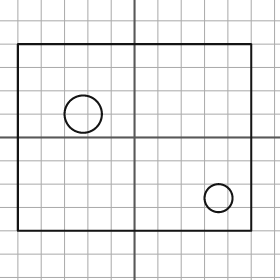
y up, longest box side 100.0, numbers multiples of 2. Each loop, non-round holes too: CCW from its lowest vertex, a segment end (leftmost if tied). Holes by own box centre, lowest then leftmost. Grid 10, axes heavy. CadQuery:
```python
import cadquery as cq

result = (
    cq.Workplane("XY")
    .moveTo(-50.0, -40.0)
    .lineTo(50.0, -40.0)
    .lineTo(50.0, 40.0)
    .lineTo(-50.0, 40.0)
    .close()
    .moveTo(36.0, -26.0)
    .circle(6.0)
    .moveTo(-22.0, 10.0)
    .circle(8.0)
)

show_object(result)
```